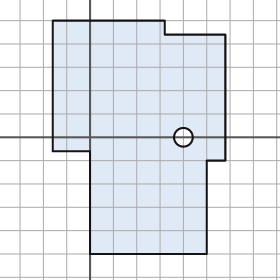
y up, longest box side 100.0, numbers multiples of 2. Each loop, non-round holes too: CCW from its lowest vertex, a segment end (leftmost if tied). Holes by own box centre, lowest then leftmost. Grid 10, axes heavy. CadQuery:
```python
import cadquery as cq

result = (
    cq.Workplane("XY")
    .moveTo(0.0, -50.0)
    .lineTo(50.0, -50.0)
    .lineTo(50.0, -10.0)
    .lineTo(58.0, -10.0)
    .lineTo(58.0, 44.0)
    .lineTo(32.0, 44.0)
    .lineTo(32.0, 50.0)
    .lineTo(-16.0, 50.0)
    .lineTo(-16.0, -6.0)
    .lineTo(0.0, -6.0)
    .close()
    .moveTo(40.0, 0.0)
    .circle(4.0)
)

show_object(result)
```